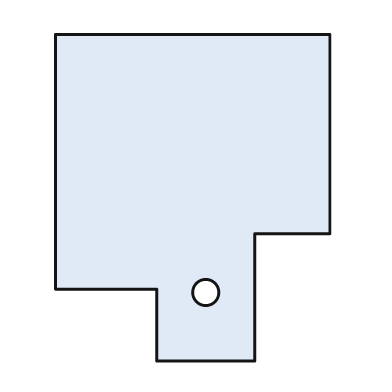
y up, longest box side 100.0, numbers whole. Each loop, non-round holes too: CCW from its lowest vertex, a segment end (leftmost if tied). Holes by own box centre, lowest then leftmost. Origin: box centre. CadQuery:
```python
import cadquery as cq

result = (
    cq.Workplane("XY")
    .moveTo(-11.0, -50.0)
    .lineTo(19.0, -50.0)
    .lineTo(19.0, -11.0)
    .lineTo(42.0, -11.0)
    .lineTo(42.0, 50.0)
    .lineTo(-42.0, 50.0)
    .lineTo(-42.0, -28.0)
    .lineTo(-11.0, -28.0)
    .close()
    .moveTo(4.0, -29.0)
    .circle(4.0)
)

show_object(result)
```